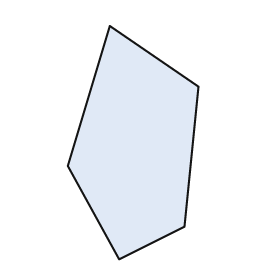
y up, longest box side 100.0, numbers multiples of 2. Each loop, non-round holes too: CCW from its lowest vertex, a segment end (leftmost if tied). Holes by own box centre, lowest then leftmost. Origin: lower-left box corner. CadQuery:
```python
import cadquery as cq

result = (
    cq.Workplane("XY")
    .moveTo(22.0, 0.0)
    .lineTo(50.0, 14.0)
    .lineTo(56.0, 74.0)
    .lineTo(18.0, 100.0)
    .lineTo(0.0, 40.0)
    .close()
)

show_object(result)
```